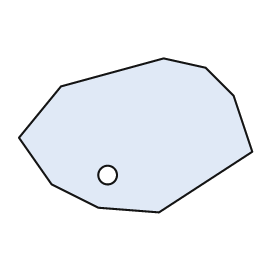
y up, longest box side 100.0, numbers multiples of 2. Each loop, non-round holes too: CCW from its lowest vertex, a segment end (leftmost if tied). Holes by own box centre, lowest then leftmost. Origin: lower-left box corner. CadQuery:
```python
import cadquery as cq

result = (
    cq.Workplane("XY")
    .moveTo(60.0, 0.0)
    .lineTo(100.0, 26.0)
    .lineTo(92.0, 50.0)
    .lineTo(80.0, 62.0)
    .lineTo(62.0, 66.0)
    .lineTo(18.0, 54.0)
    .lineTo(0.0, 32.0)
    .lineTo(14.0, 12.0)
    .lineTo(34.0, 2.0)
    .close()
    .moveTo(38.0, 16.0)
    .circle(4.0)
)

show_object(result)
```